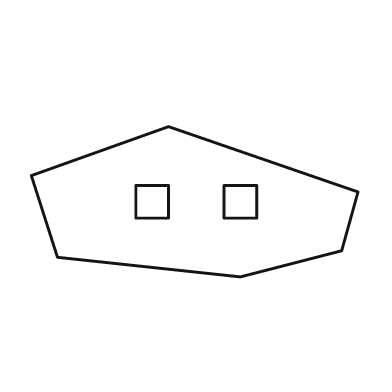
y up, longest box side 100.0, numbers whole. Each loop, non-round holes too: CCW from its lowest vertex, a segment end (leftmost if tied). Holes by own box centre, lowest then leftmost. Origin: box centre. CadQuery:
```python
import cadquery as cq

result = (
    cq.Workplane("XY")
    .moveTo(14.0, -23.0)
    .lineTo(45.0, -15.0)
    .lineTo(50.0, 3.0)
    .lineTo(-8.0, 23.0)
    .lineTo(-50.0, 8.0)
    .lineTo(-42.0, -17.0)
    .close()
    .moveTo(-18.0, -5.0)
    .lineTo(-8.0, -5.0)
    .lineTo(-8.0, 5.0)
    .lineTo(-18.0, 5.0)
    .close()
    .moveTo(9.0, -5.0)
    .lineTo(19.0, -5.0)
    .lineTo(19.0, 5.0)
    .lineTo(9.0, 5.0)
    .close()
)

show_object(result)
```